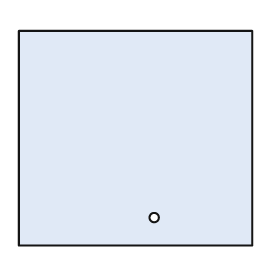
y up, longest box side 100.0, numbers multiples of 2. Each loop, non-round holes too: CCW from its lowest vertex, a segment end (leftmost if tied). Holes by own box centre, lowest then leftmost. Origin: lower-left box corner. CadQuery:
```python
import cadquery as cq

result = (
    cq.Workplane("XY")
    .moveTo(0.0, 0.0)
    .lineTo(100.0, 0.0)
    .lineTo(100.0, 92.0)
    .lineTo(0.0, 92.0)
    .close()
    .moveTo(58.0, 12.0)
    .circle(2.0)
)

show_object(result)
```